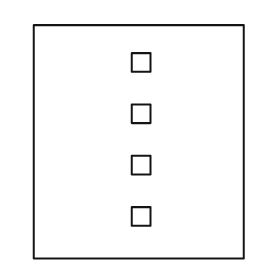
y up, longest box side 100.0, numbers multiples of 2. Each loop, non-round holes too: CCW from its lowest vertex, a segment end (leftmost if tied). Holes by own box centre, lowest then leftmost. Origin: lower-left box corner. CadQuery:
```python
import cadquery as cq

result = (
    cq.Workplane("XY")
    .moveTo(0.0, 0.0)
    .lineTo(90.0, 0.0)
    .lineTo(90.0, 100.0)
    .lineTo(0.0, 100.0)
    .close()
    .moveTo(42.0, 14.0)
    .lineTo(50.0, 14.0)
    .lineTo(50.0, 22.0)
    .lineTo(42.0, 22.0)
    .close()
    .moveTo(42.0, 36.0)
    .lineTo(50.0, 36.0)
    .lineTo(50.0, 44.0)
    .lineTo(42.0, 44.0)
    .close()
    .moveTo(42.0, 58.0)
    .lineTo(50.0, 58.0)
    .lineTo(50.0, 66.0)
    .lineTo(42.0, 66.0)
    .close()
    .moveTo(42.0, 80.0)
    .lineTo(50.0, 80.0)
    .lineTo(50.0, 88.0)
    .lineTo(42.0, 88.0)
    .close()
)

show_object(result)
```